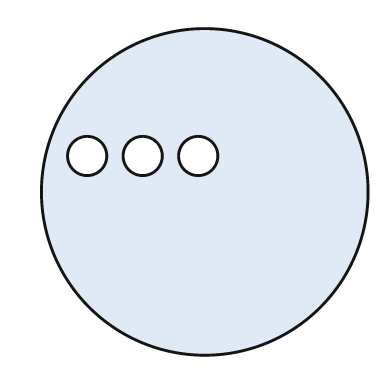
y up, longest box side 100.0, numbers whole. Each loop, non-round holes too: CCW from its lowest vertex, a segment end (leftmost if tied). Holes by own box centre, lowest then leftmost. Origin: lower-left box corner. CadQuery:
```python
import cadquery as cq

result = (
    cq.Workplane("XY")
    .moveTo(50.0, 50.0)
    .circle(50.0)
    .moveTo(14.0, 61.0)
    .circle(6.0)
    .moveTo(31.0, 61.0)
    .circle(6.0)
    .moveTo(48.0, 61.0)
    .circle(6.0)
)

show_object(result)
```